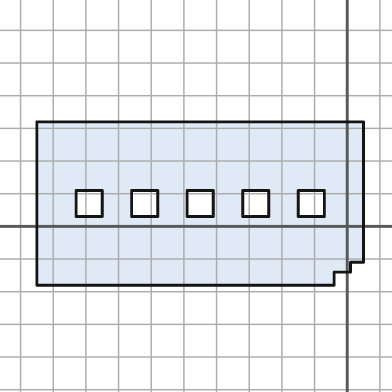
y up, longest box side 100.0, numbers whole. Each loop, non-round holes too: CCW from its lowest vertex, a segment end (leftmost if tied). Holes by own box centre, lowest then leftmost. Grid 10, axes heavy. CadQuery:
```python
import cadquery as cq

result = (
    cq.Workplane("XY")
    .moveTo(-95.0, -18.0)
    .lineTo(-4.0, -18.0)
    .lineTo(-4.0, -14.0)
    .lineTo(1.0, -14.0)
    .lineTo(1.0, -11.0)
    .lineTo(5.0, -11.0)
    .lineTo(5.0, 32.0)
    .lineTo(-95.0, 32.0)
    .close()
    .moveTo(-83.0, 3.0)
    .lineTo(-75.0, 3.0)
    .lineTo(-75.0, 11.0)
    .lineTo(-83.0, 11.0)
    .close()
    .moveTo(-66.0, 3.0)
    .lineTo(-58.0, 3.0)
    .lineTo(-58.0, 11.0)
    .lineTo(-66.0, 11.0)
    .close()
    .moveTo(-49.0, 3.0)
    .lineTo(-41.0, 3.0)
    .lineTo(-41.0, 11.0)
    .lineTo(-49.0, 11.0)
    .close()
    .moveTo(-32.0, 3.0)
    .lineTo(-24.0, 3.0)
    .lineTo(-24.0, 11.0)
    .lineTo(-32.0, 11.0)
    .close()
    .moveTo(-15.0, 3.0)
    .lineTo(-7.0, 3.0)
    .lineTo(-7.0, 11.0)
    .lineTo(-15.0, 11.0)
    .close()
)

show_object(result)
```